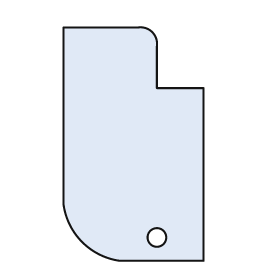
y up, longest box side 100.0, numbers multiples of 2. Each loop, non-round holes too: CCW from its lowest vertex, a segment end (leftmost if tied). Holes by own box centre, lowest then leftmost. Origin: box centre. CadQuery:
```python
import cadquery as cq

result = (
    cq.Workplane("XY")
    .moveTo(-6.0, -50.0)
    .lineTo(30.0, -50.0)
    .lineTo(30.0, 24.0)
    .lineTo(10.0, 24.0)
    .lineTo(10.0, 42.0)
    .threePointArc((8.0, 48.0), (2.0, 50.0))
    .lineTo(-30.0, 50.0)
    .lineTo(-30.0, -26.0)
    .threePointArc((-22.0, -42.0), (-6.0, -50.0))
    .close()
    .moveTo(10.0, -40.0)
    .circle(4.0)
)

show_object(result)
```